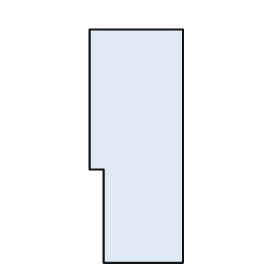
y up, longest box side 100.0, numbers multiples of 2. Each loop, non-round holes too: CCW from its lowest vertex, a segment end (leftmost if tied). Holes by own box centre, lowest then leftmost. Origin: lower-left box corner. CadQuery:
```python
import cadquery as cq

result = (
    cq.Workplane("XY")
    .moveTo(6.0, 0.0)
    .lineTo(40.0, 0.0)
    .lineTo(40.0, 100.0)
    .lineTo(0.0, 100.0)
    .lineTo(0.0, 40.0)
    .lineTo(6.0, 40.0)
    .close()
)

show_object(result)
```